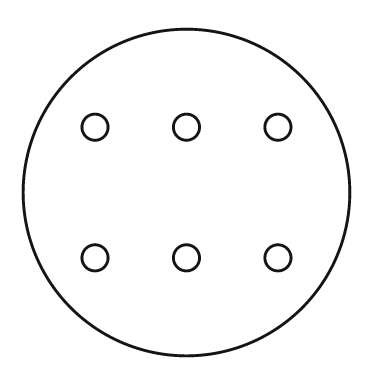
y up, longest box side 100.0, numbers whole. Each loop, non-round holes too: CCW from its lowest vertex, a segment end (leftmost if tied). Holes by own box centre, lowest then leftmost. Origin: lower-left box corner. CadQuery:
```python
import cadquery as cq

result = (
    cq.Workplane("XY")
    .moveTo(50.0, 50.0)
    .circle(50.0)
    .moveTo(22.0, 30.0)
    .circle(4.0)
    .moveTo(50.0, 30.0)
    .circle(4.0)
    .moveTo(78.0, 30.0)
    .circle(4.0)
    .moveTo(22.0, 70.0)
    .circle(4.0)
    .moveTo(50.0, 70.0)
    .circle(4.0)
    .moveTo(78.0, 70.0)
    .circle(4.0)
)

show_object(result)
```